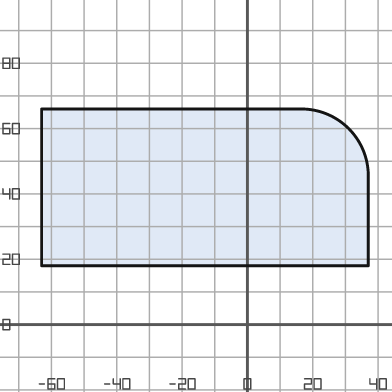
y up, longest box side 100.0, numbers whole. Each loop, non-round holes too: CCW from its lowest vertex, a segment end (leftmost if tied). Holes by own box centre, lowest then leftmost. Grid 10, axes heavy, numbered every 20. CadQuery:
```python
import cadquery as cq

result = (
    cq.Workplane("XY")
    .moveTo(-63.0, 18.0)
    .lineTo(37.0, 18.0)
    .lineTo(37.0, 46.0)
    .threePointArc((31.0, 60.0), (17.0, 66.0))
    .lineTo(-63.0, 66.0)
    .close()
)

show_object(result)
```